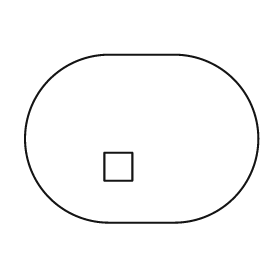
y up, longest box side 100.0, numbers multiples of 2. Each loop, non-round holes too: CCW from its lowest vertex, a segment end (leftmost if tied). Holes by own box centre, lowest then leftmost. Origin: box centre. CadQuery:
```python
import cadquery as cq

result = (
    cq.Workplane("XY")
    .moveTo(-14.0, -36.0)
    .lineTo(14.0, -36.0)
    .threePointArc((50.0, 0.0), (14.0, 36.0))
    .lineTo(-14.0, 36.0)
    .threePointArc((-50.0, 0.0), (-14.0, -36.0))
    .close()
    .moveTo(-16.0, -18.0)
    .lineTo(-4.0, -18.0)
    .lineTo(-4.0, -6.0)
    .lineTo(-16.0, -6.0)
    .close()
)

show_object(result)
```